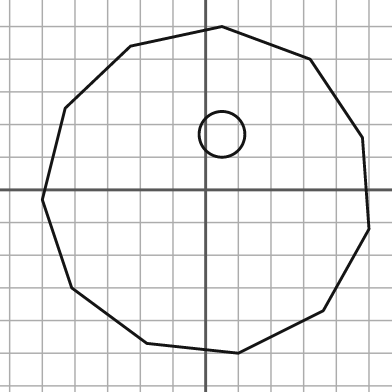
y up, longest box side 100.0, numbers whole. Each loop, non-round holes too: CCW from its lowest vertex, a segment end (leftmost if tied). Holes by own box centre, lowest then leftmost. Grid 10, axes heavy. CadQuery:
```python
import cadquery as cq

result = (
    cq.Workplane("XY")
    .moveTo(10.0, -50.0)
    .lineTo(36.0, -37.0)
    .lineTo(50.0, -12.0)
    .lineTo(48.0, 16.0)
    .lineTo(32.0, 40.0)
    .lineTo(5.0, 50.0)
    .lineTo(-23.0, 44.0)
    .lineTo(-43.0, 25.0)
    .lineTo(-50.0, -3.0)
    .lineTo(-41.0, -30.0)
    .lineTo(-18.0, -47.0)
    .close()
    .moveTo(5.0, 17.0)
    .circle(7.0)
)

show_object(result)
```